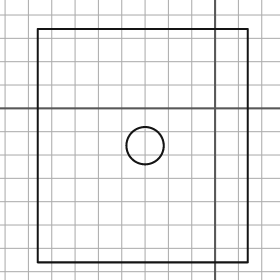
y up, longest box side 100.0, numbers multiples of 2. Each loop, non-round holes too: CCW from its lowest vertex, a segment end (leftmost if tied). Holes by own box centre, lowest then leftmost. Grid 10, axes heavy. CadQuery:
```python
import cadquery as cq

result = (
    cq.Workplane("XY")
    .moveTo(-76.0, -66.0)
    .lineTo(14.0, -66.0)
    .lineTo(14.0, 34.0)
    .lineTo(-76.0, 34.0)
    .close()
    .moveTo(-30.0, -16.0)
    .circle(8.0)
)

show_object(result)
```